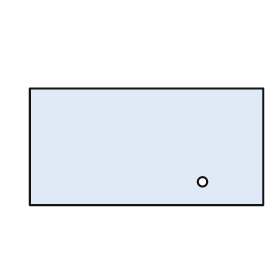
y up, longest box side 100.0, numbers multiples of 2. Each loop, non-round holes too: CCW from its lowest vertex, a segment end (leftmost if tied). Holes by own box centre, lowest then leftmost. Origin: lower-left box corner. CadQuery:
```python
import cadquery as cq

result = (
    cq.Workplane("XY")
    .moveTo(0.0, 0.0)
    .lineTo(100.0, 0.0)
    .lineTo(100.0, 50.0)
    .lineTo(0.0, 50.0)
    .close()
    .moveTo(74.0, 10.0)
    .circle(2.0)
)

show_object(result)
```